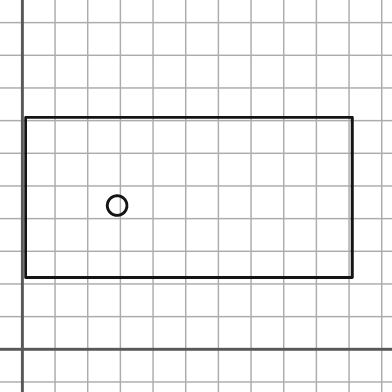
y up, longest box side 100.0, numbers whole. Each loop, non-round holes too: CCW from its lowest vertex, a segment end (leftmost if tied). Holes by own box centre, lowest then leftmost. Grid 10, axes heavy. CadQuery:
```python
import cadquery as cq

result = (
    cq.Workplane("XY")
    .moveTo(1.0, 22.0)
    .lineTo(101.0, 22.0)
    .lineTo(101.0, 71.0)
    .lineTo(1.0, 71.0)
    .close()
    .moveTo(29.0, 44.0)
    .circle(3.0)
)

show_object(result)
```